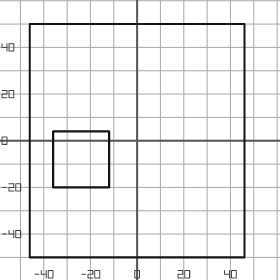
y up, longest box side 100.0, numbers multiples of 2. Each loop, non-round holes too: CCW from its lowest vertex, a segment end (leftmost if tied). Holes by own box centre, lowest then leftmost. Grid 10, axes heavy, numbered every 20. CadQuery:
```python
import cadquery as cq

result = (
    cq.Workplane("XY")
    .moveTo(-46.0, -50.0)
    .lineTo(46.0, -50.0)
    .lineTo(46.0, 50.0)
    .lineTo(-46.0, 50.0)
    .close()
    .moveTo(-36.0, -20.0)
    .lineTo(-12.0, -20.0)
    .lineTo(-12.0, 4.0)
    .lineTo(-36.0, 4.0)
    .close()
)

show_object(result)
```